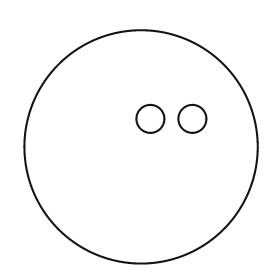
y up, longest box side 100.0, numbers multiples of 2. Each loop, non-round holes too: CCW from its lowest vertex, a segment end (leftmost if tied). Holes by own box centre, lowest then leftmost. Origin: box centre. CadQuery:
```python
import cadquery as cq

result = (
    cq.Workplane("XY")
    .moveTo(0.0, 0.0)
    .circle(50.0)
    .moveTo(4.0, 12.0)
    .circle(6.0)
    .moveTo(22.0, 12.0)
    .circle(6.0)
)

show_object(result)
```